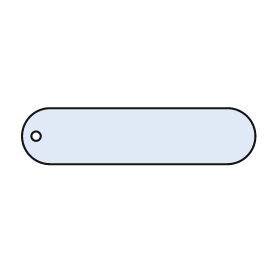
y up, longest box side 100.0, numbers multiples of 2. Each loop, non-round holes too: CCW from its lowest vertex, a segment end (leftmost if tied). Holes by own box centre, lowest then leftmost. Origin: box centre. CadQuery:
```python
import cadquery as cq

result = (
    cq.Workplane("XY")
    .moveTo(-38.0, -12.0)
    .lineTo(38.0, -12.0)
    .threePointArc((50.0, 0.0), (38.0, 12.0))
    .lineTo(-38.0, 12.0)
    .threePointArc((-50.0, 0.0), (-38.0, -12.0))
    .close()
    .moveTo(-44.0, 0.0)
    .circle(2.0)
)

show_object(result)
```